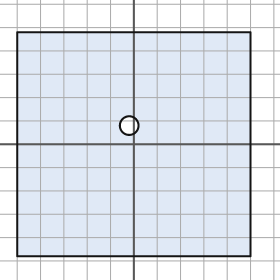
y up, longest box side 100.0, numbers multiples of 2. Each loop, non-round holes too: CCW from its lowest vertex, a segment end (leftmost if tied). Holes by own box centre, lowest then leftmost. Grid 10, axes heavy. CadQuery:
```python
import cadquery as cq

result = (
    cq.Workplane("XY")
    .moveTo(-50.0, -48.0)
    .lineTo(50.0, -48.0)
    .lineTo(50.0, 48.0)
    .lineTo(-50.0, 48.0)
    .close()
    .moveTo(-2.0, 8.0)
    .circle(4.0)
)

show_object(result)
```